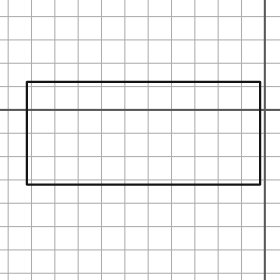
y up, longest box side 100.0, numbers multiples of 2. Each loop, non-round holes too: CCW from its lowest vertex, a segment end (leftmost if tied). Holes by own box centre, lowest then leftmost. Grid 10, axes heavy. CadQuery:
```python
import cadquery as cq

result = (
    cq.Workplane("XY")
    .moveTo(-102.0, -32.0)
    .lineTo(-2.0, -32.0)
    .lineTo(-2.0, 12.0)
    .lineTo(-102.0, 12.0)
    .close()
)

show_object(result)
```